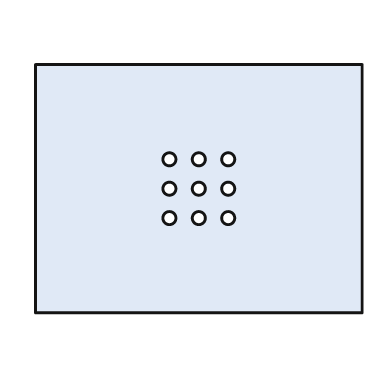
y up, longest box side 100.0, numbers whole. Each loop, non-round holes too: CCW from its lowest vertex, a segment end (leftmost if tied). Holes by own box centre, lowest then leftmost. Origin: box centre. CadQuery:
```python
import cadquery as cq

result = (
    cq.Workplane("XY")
    .moveTo(-50.0, -38.0)
    .lineTo(50.0, -38.0)
    .lineTo(50.0, 38.0)
    .lineTo(-50.0, 38.0)
    .close()
    .moveTo(-9.0, -9.0)
    .circle(2.0)
    .moveTo(0.0, -9.0)
    .circle(2.0)
    .moveTo(9.0, -9.0)
    .circle(2.0)
    .moveTo(-9.0, 0.0)
    .circle(2.0)
    .moveTo(0.0, 0.0)
    .circle(2.0)
    .moveTo(9.0, 0.0)
    .circle(2.0)
    .moveTo(-9.0, 9.0)
    .circle(2.0)
    .moveTo(0.0, 9.0)
    .circle(2.0)
    .moveTo(9.0, 9.0)
    .circle(2.0)
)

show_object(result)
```